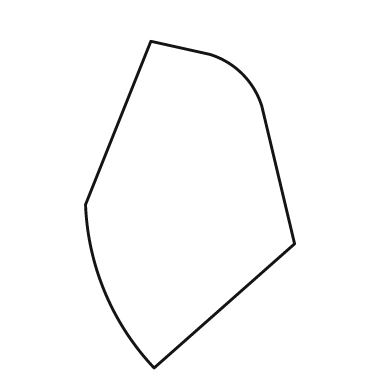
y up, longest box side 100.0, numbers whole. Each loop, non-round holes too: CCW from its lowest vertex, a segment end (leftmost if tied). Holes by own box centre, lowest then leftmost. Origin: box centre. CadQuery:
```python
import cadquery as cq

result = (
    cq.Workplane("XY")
    .moveTo(-11.0, -50.0)
    .lineTo(32.0, -12.0)
    .lineTo(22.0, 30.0)
    .threePointArc((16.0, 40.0), (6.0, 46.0))
    .lineTo(-12.0, 50.0)
    .lineTo(-32.0, 0.0)
    .threePointArc((-26.0, -27.0), (-11.0, -50.0))
    .close()
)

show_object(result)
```